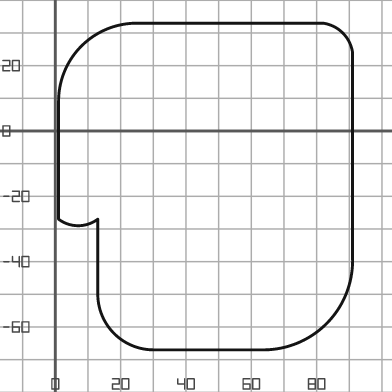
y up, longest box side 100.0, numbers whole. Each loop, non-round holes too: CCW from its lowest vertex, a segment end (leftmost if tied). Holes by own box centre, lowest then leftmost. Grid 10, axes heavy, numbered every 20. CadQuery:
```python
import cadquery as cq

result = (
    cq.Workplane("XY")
    .moveTo(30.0, -67.0)
    .lineTo(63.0, -67.0)
    .threePointArc((83.0, -59.0), (91.0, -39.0))
    .lineTo(91.0, 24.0)
    .threePointArc((88.0, 30.0), (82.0, 33.0))
    .lineTo(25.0, 33.0)
    .threePointArc((8.0, 26.0), (1.0, 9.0))
    .lineTo(1.0, -27.0)
    .threePointArc((7.0, -29.0), (13.0, -27.0))
    .lineTo(13.0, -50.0)
    .threePointArc((18.0, -62.0), (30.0, -67.0))
    .close()
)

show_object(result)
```